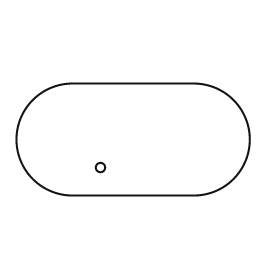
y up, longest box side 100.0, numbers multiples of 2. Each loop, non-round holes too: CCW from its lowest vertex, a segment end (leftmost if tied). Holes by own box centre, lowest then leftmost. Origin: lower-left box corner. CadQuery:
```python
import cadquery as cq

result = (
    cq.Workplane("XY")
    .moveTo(24.0, 0.0)
    .lineTo(76.0, 0.0)
    .threePointArc((100.0, 24.0), (76.0, 48.0))
    .lineTo(24.0, 48.0)
    .threePointArc((0.0, 24.0), (24.0, 0.0))
    .close()
    .moveTo(36.0, 12.0)
    .circle(2.0)
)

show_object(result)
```